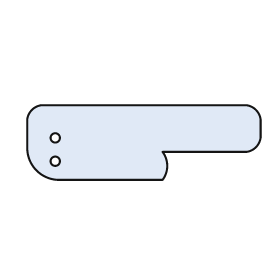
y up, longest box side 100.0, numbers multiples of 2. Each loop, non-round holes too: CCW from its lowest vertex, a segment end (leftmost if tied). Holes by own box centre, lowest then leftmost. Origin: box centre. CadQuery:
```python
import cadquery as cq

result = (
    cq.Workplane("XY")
    .moveTo(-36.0, -16.0)
    .lineTo(8.0, -16.0)
    .threePointArc((10.0, -10.0), (8.0, -4.0))
    .lineTo(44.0, -4.0)
    .threePointArc((48.0, -2.0), (50.0, 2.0))
    .lineTo(50.0, 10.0)
    .threePointArc((48.0, 14.0), (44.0, 16.0))
    .lineTo(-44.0, 16.0)
    .threePointArc((-48.0, 14.0), (-50.0, 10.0))
    .lineTo(-50.0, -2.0)
    .threePointArc((-46.0, -12.0), (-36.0, -16.0))
    .close()
    .moveTo(-38.0, -8.0)
    .circle(2.0)
    .moveTo(-38.0, 2.0)
    .circle(2.0)
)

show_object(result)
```